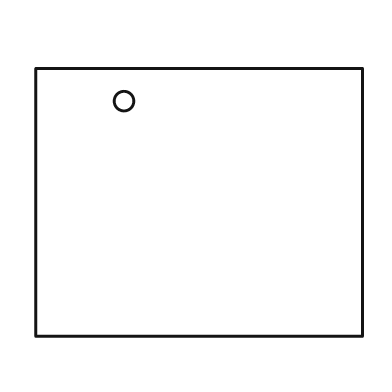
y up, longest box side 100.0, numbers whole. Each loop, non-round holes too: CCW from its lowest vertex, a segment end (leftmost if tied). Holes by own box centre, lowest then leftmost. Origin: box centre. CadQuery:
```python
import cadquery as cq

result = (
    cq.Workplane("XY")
    .moveTo(-50.0, -41.0)
    .lineTo(50.0, -41.0)
    .lineTo(50.0, 41.0)
    .lineTo(-50.0, 41.0)
    .close()
    .moveTo(-23.0, 31.0)
    .circle(3.0)
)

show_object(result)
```